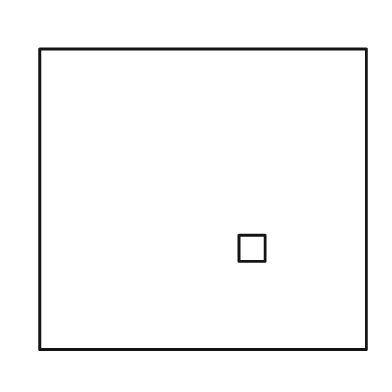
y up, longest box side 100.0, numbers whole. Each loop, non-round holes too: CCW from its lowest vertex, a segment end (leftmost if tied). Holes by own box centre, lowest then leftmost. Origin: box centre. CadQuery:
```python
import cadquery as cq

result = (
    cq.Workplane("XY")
    .moveTo(-50.0, -46.0)
    .lineTo(50.0, -46.0)
    .lineTo(50.0, 46.0)
    .lineTo(-50.0, 46.0)
    .close()
    .moveTo(11.0, -19.0)
    .lineTo(19.0, -19.0)
    .lineTo(19.0, -11.0)
    .lineTo(11.0, -11.0)
    .close()
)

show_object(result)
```